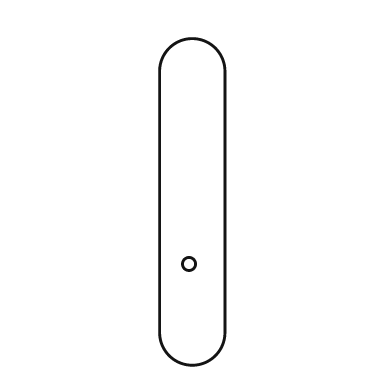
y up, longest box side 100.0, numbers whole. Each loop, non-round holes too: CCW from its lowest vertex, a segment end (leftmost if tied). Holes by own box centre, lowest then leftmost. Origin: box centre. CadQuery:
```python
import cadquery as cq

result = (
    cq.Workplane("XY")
    .moveTo(-10.0, -40.0)
    .threePointArc((0.0, -50.0), (10.0, -40.0))
    .lineTo(10.0, 40.0)
    .threePointArc((0.0, 50.0), (-10.0, 40.0))
    .close()
    .moveTo(-1.0, -19.0)
    .circle(2.0)
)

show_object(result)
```